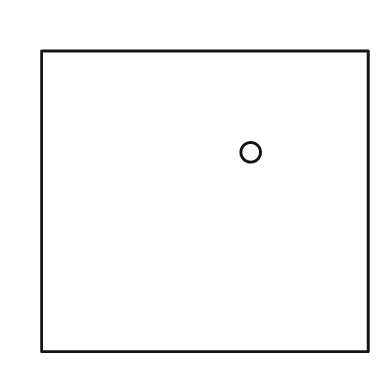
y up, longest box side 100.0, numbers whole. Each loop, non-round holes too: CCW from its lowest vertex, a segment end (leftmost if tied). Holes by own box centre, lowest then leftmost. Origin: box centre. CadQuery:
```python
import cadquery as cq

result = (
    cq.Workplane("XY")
    .moveTo(-50.0, -46.0)
    .lineTo(50.0, -46.0)
    .lineTo(50.0, 46.0)
    .lineTo(-50.0, 46.0)
    .close()
    .moveTo(14.0, 15.0)
    .circle(3.0)
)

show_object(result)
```